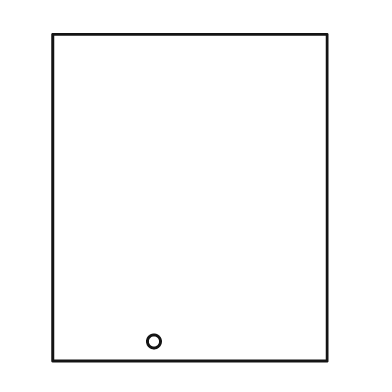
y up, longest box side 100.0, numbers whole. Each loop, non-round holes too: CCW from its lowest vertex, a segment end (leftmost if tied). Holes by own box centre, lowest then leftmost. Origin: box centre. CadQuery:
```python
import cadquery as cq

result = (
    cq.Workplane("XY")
    .moveTo(-42.0, -50.0)
    .lineTo(42.0, -50.0)
    .lineTo(42.0, 50.0)
    .lineTo(-42.0, 50.0)
    .close()
    .moveTo(-11.0, -44.0)
    .circle(2.0)
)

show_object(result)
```